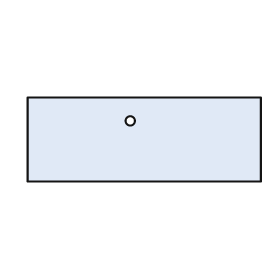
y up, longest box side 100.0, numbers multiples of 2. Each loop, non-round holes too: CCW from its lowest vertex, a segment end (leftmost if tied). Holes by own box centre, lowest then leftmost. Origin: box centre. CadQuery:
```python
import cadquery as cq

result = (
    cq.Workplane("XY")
    .moveTo(-50.0, -18.0)
    .lineTo(50.0, -18.0)
    .lineTo(50.0, 18.0)
    .lineTo(-50.0, 18.0)
    .close()
    .moveTo(-6.0, 8.0)
    .circle(2.0)
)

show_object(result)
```